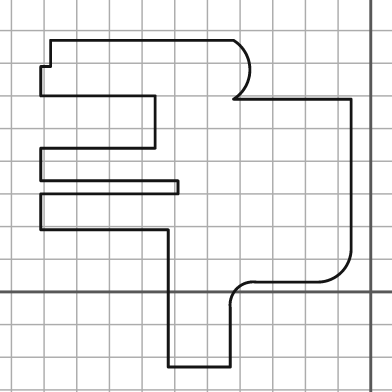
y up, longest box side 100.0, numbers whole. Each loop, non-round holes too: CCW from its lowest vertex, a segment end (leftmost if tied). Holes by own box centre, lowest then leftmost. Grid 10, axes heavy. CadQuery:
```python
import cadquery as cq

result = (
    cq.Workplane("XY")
    .moveTo(-62.0, -23.0)
    .lineTo(-43.0, -23.0)
    .lineTo(-43.0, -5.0)
    .threePointArc((-41.0, 1.0), (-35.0, 3.0))
    .lineTo(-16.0, 3.0)
    .threePointArc((-9.0, 6.0), (-6.0, 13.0))
    .lineTo(-6.0, 59.0)
    .lineTo(-42.0, 59.0)
    .threePointArc((-37.0, 68.0), (-42.0, 77.0))
    .lineTo(-98.0, 77.0)
    .lineTo(-98.0, 69.0)
    .lineTo(-101.0, 69.0)
    .lineTo(-101.0, 60.0)
    .lineTo(-66.0, 60.0)
    .lineTo(-66.0, 44.0)
    .lineTo(-101.0, 44.0)
    .lineTo(-101.0, 34.0)
    .lineTo(-59.0, 34.0)
    .lineTo(-59.0, 30.0)
    .lineTo(-101.0, 30.0)
    .lineTo(-101.0, 19.0)
    .lineTo(-62.0, 19.0)
    .close()
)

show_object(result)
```